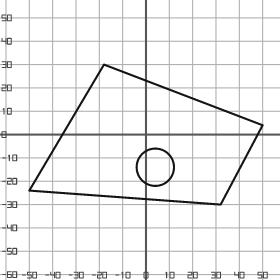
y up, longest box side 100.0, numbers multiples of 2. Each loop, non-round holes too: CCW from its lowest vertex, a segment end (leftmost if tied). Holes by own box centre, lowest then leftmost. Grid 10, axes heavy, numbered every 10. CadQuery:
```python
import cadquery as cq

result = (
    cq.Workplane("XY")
    .moveTo(32.0, -30.0)
    .lineTo(50.0, 4.0)
    .lineTo(-18.0, 30.0)
    .lineTo(-50.0, -24.0)
    .close()
    .moveTo(4.0, -14.0)
    .circle(8.0)
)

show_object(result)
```